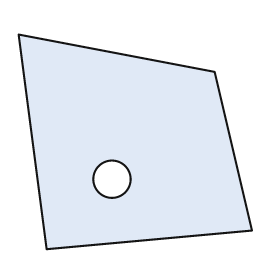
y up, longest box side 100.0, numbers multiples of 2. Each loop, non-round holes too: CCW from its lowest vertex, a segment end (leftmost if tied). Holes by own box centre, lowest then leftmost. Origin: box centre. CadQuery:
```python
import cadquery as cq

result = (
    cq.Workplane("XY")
    .moveTo(-38.0, -46.0)
    .lineTo(50.0, -38.0)
    .lineTo(34.0, 30.0)
    .lineTo(-50.0, 46.0)
    .close()
    .moveTo(-10.0, -16.0)
    .circle(8.0)
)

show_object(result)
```